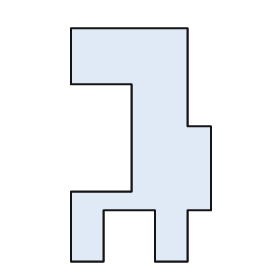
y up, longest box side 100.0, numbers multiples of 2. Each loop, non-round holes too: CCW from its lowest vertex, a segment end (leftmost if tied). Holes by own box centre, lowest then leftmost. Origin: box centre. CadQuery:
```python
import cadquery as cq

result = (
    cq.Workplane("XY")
    .moveTo(-30.0, -50.0)
    .lineTo(-16.0, -50.0)
    .lineTo(-16.0, -28.0)
    .lineTo(6.0, -28.0)
    .lineTo(6.0, -50.0)
    .lineTo(20.0, -50.0)
    .lineTo(20.0, -28.0)
    .lineTo(30.0, -28.0)
    .lineTo(30.0, 8.0)
    .lineTo(20.0, 8.0)
    .lineTo(20.0, 50.0)
    .lineTo(-30.0, 50.0)
    .lineTo(-30.0, 26.0)
    .lineTo(-4.0, 26.0)
    .lineTo(-4.0, -20.0)
    .lineTo(-30.0, -20.0)
    .close()
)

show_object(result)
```